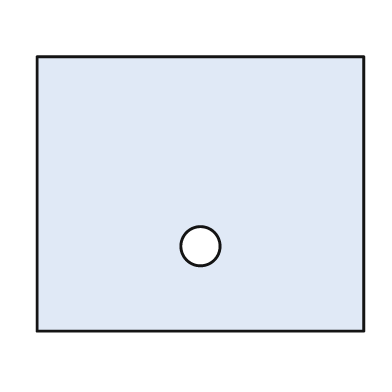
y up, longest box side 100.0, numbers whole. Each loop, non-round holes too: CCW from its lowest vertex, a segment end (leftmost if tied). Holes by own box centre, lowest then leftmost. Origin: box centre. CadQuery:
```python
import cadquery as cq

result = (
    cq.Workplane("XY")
    .moveTo(-50.0, -42.0)
    .lineTo(50.0, -42.0)
    .lineTo(50.0, 42.0)
    .lineTo(-50.0, 42.0)
    .close()
    .moveTo(0.0, -16.0)
    .circle(6.0)
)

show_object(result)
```